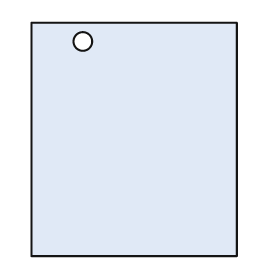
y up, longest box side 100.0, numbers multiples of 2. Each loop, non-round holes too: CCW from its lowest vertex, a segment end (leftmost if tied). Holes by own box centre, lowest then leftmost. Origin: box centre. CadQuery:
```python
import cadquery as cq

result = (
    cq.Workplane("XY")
    .moveTo(-44.0, -50.0)
    .lineTo(44.0, -50.0)
    .lineTo(44.0, 50.0)
    .lineTo(-44.0, 50.0)
    .close()
    .moveTo(-22.0, 42.0)
    .circle(4.0)
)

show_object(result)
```